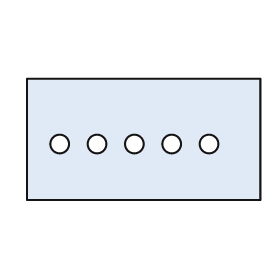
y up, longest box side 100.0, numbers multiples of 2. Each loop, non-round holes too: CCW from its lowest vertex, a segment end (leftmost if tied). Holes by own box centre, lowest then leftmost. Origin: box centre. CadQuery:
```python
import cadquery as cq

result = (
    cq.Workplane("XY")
    .moveTo(-50.0, -26.0)
    .lineTo(50.0, -26.0)
    .lineTo(50.0, 26.0)
    .lineTo(-50.0, 26.0)
    .close()
    .moveTo(-36.0, -2.0)
    .circle(4.0)
    .moveTo(-20.0, -2.0)
    .circle(4.0)
    .moveTo(-4.0, -2.0)
    .circle(4.0)
    .moveTo(12.0, -2.0)
    .circle(4.0)
    .moveTo(28.0, -2.0)
    .circle(4.0)
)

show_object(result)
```